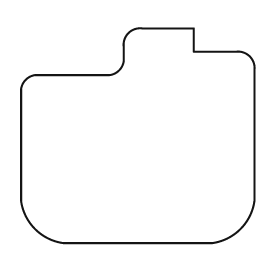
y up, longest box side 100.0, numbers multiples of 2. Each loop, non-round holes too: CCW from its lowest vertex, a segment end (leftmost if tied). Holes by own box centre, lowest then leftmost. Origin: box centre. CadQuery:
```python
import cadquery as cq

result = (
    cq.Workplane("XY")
    .moveTo(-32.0, -46.0)
    .lineTo(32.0, -46.0)
    .threePointArc((44.0, -40.0), (50.0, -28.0))
    .lineTo(50.0, 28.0)
    .threePointArc((48.0, 34.0), (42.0, 36.0))
    .lineTo(24.0, 36.0)
    .lineTo(24.0, 46.0)
    .lineTo(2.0, 46.0)
    .threePointArc((-4.0, 44.0), (-6.0, 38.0))
    .lineTo(-6.0, 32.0)
    .threePointArc((-8.0, 28.0), (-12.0, 26.0))
    .lineTo(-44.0, 26.0)
    .threePointArc((-48.0, 24.0), (-50.0, 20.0))
    .lineTo(-50.0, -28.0)
    .threePointArc((-44.0, -40.0), (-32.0, -46.0))
    .close()
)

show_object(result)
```